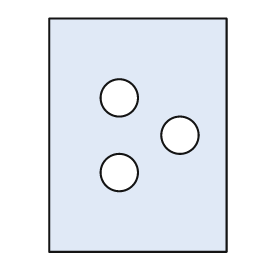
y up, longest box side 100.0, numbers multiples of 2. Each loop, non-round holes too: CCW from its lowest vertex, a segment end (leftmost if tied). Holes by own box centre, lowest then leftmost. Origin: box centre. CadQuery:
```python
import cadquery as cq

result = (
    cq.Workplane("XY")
    .moveTo(-38.0, -50.0)
    .lineTo(38.0, -50.0)
    .lineTo(38.0, 50.0)
    .lineTo(-38.0, 50.0)
    .close()
    .moveTo(-8.0, -16.0)
    .circle(8.0)
    .moveTo(18.0, 0.0)
    .circle(8.0)
    .moveTo(-8.0, 16.0)
    .circle(8.0)
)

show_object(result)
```